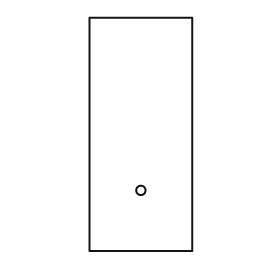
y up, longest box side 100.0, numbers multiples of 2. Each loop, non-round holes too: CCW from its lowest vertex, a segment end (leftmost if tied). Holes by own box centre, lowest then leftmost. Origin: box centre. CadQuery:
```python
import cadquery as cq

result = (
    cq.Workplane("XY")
    .moveTo(-22.0, -50.0)
    .lineTo(22.0, -50.0)
    .lineTo(22.0, 50.0)
    .lineTo(-22.0, 50.0)
    .close()
    .moveTo(0.0, -24.0)
    .circle(2.0)
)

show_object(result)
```